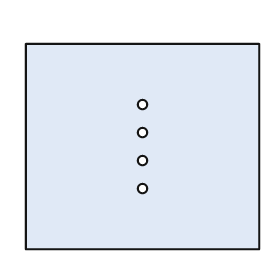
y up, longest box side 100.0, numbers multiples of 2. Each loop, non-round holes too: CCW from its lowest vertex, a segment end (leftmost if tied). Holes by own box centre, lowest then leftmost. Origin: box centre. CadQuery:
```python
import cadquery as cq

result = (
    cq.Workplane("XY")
    .moveTo(-50.0, -44.0)
    .lineTo(50.0, -44.0)
    .lineTo(50.0, 44.0)
    .lineTo(-50.0, 44.0)
    .close()
    .moveTo(0.0, -18.0)
    .circle(2.0)
    .moveTo(0.0, -6.0)
    .circle(2.0)
    .moveTo(0.0, 6.0)
    .circle(2.0)
    .moveTo(0.0, 18.0)
    .circle(2.0)
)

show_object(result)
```